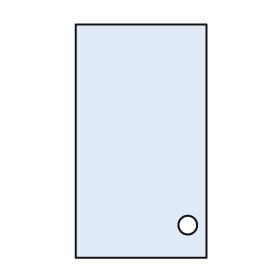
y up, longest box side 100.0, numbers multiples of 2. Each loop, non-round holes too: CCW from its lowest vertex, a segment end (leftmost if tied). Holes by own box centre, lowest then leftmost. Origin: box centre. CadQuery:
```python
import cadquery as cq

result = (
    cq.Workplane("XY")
    .moveTo(-28.0, -50.0)
    .lineTo(28.0, -50.0)
    .lineTo(28.0, 50.0)
    .lineTo(-28.0, 50.0)
    .close()
    .moveTo(20.0, -36.0)
    .circle(4.0)
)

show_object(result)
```